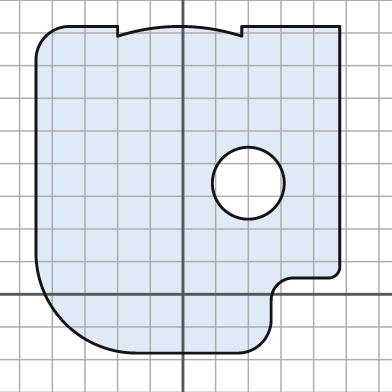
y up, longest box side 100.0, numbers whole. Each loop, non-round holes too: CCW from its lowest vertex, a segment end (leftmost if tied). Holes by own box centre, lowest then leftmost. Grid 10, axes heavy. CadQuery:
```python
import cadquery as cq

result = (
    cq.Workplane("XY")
    .moveTo(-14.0, -18.0)
    .lineTo(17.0, -18.0)
    .threePointArc((24.0, -15.0), (27.0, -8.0))
    .lineTo(27.0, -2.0)
    .threePointArc((29.0, 3.0), (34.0, 5.0))
    .lineTo(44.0, 5.0)
    .threePointArc((47.0, 6.0), (48.0, 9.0))
    .lineTo(48.0, 82.0)
    .lineTo(18.0, 82.0)
    .lineTo(18.0, 79.0)
    .threePointArc((-1.0, 82.0), (-20.0, 79.0))
    .lineTo(-20.0, 82.0)
    .lineTo(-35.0, 82.0)
    .threePointArc((-42.0, 79.0), (-45.0, 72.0))
    .lineTo(-45.0, 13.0)
    .threePointArc((-36.0, -9.0), (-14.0, -18.0))
    .close()
    .moveTo(20.0, 34.0)
    .circle(11.0)
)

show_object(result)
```